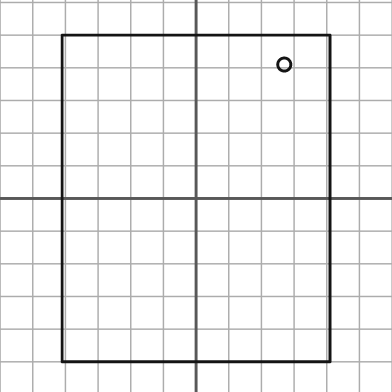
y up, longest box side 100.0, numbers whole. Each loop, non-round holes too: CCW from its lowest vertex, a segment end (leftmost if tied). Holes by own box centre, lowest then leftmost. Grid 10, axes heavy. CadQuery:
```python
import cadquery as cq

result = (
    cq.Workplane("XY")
    .moveTo(-41.0, -50.0)
    .lineTo(41.0, -50.0)
    .lineTo(41.0, 50.0)
    .lineTo(-41.0, 50.0)
    .close()
    .moveTo(27.0, 41.0)
    .circle(2.0)
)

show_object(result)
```